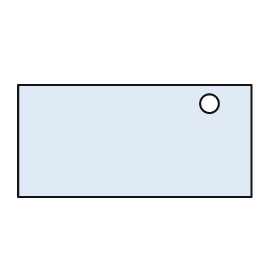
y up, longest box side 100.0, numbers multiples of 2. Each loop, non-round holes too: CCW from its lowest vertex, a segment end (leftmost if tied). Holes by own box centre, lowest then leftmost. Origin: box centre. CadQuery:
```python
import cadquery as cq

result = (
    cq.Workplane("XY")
    .moveTo(-50.0, -24.0)
    .lineTo(50.0, -24.0)
    .lineTo(50.0, 24.0)
    .lineTo(-50.0, 24.0)
    .close()
    .moveTo(32.0, 16.0)
    .circle(4.0)
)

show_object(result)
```